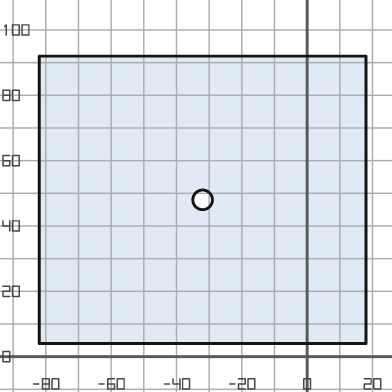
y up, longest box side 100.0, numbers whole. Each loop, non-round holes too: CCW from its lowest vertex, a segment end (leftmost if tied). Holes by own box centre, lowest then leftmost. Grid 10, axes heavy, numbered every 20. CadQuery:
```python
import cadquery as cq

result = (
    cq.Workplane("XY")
    .moveTo(-82.0, 4.0)
    .lineTo(18.0, 4.0)
    .lineTo(18.0, 92.0)
    .lineTo(-82.0, 92.0)
    .close()
    .moveTo(-32.0, 48.0)
    .circle(3.0)
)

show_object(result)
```